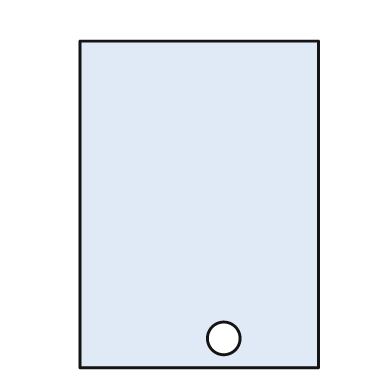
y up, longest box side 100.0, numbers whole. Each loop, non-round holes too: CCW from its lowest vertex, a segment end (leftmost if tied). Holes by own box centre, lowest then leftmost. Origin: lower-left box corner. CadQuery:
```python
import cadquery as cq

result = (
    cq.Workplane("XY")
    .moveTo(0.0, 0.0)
    .lineTo(73.0, 0.0)
    .lineTo(73.0, 100.0)
    .lineTo(0.0, 100.0)
    .close()
    .moveTo(44.0, 9.0)
    .circle(5.0)
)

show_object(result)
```